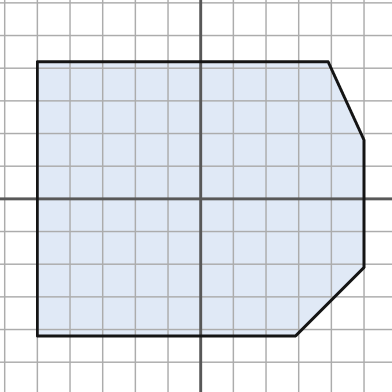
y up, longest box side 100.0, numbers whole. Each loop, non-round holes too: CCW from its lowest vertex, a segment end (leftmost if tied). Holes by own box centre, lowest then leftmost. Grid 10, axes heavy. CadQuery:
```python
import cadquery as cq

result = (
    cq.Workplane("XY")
    .moveTo(-50.0, -42.0)
    .lineTo(29.0, -42.0)
    .lineTo(50.0, -21.0)
    .lineTo(50.0, 18.0)
    .lineTo(39.0, 42.0)
    .lineTo(-50.0, 42.0)
    .close()
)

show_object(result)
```